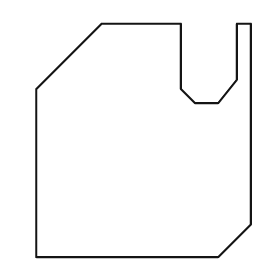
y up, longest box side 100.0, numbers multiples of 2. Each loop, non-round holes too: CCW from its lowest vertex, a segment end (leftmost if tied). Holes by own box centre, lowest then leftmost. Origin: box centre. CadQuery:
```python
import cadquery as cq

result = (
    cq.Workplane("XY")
    .moveTo(-46.0, -50.0)
    .lineTo(32.0, -50.0)
    .lineTo(46.0, -36.0)
    .lineTo(46.0, 50.0)
    .lineTo(40.0, 50.0)
    .lineTo(40.0, 26.0)
    .lineTo(32.0, 16.0)
    .lineTo(22.0, 16.0)
    .lineTo(16.0, 22.0)
    .lineTo(16.0, 50.0)
    .lineTo(-18.0, 50.0)
    .lineTo(-46.0, 22.0)
    .close()
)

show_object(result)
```